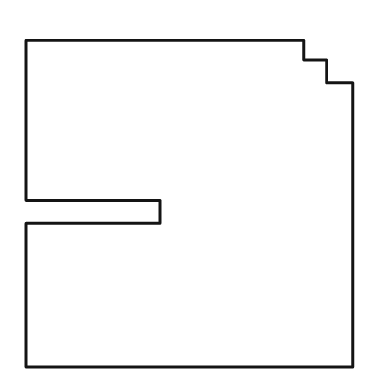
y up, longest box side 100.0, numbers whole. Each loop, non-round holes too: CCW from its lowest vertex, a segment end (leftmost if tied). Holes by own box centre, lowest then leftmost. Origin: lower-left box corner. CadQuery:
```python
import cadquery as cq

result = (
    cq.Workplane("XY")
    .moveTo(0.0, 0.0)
    .lineTo(100.0, 0.0)
    .lineTo(100.0, 87.0)
    .lineTo(92.0, 87.0)
    .lineTo(92.0, 94.0)
    .lineTo(85.0, 94.0)
    .lineTo(85.0, 100.0)
    .lineTo(0.0, 100.0)
    .lineTo(0.0, 51.0)
    .lineTo(41.0, 51.0)
    .lineTo(41.0, 44.0)
    .lineTo(0.0, 44.0)
    .close()
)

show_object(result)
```